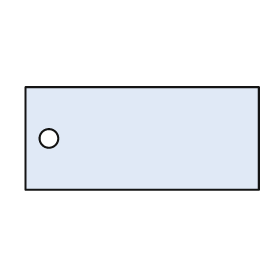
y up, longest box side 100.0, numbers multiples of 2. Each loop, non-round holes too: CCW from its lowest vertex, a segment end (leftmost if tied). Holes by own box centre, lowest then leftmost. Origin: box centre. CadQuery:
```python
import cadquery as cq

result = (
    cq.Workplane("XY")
    .moveTo(-50.0, -22.0)
    .lineTo(50.0, -22.0)
    .lineTo(50.0, 22.0)
    .lineTo(-50.0, 22.0)
    .close()
    .moveTo(-40.0, 0.0)
    .circle(4.0)
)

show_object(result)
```